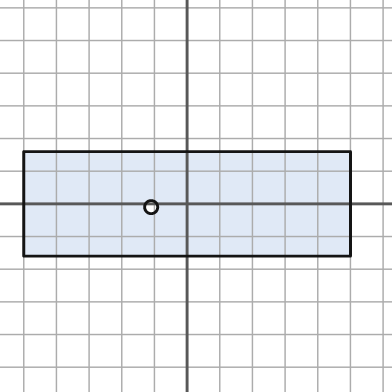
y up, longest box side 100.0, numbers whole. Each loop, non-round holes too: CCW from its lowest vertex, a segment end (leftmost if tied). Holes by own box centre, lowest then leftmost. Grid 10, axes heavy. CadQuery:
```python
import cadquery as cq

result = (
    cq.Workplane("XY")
    .moveTo(-50.0, -16.0)
    .lineTo(50.0, -16.0)
    .lineTo(50.0, 16.0)
    .lineTo(-50.0, 16.0)
    .close()
    .moveTo(-11.0, -1.0)
    .circle(2.0)
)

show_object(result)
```